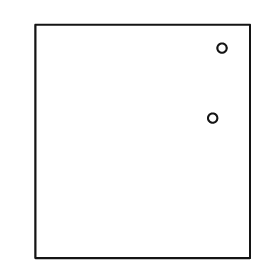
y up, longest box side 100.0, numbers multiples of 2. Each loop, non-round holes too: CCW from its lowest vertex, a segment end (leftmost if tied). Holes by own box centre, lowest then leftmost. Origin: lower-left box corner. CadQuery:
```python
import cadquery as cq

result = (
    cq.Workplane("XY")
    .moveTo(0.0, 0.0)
    .lineTo(92.0, 0.0)
    .lineTo(92.0, 100.0)
    .lineTo(0.0, 100.0)
    .close()
    .moveTo(76.0, 60.0)
    .circle(2.0)
    .moveTo(80.0, 90.0)
    .circle(2.0)
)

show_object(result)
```